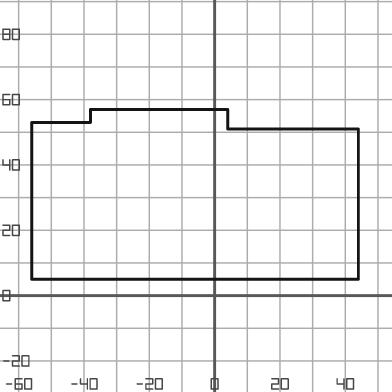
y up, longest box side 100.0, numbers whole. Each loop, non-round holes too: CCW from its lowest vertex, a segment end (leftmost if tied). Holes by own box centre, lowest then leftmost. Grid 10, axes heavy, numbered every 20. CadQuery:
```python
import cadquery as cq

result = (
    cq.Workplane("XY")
    .moveTo(-56.0, 5.0)
    .lineTo(44.0, 5.0)
    .lineTo(44.0, 51.0)
    .lineTo(4.0, 51.0)
    .lineTo(4.0, 57.0)
    .lineTo(-38.0, 57.0)
    .lineTo(-38.0, 53.0)
    .lineTo(-56.0, 53.0)
    .close()
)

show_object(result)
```